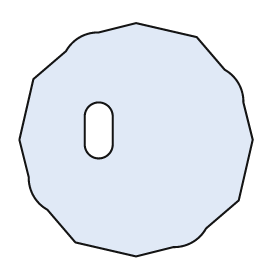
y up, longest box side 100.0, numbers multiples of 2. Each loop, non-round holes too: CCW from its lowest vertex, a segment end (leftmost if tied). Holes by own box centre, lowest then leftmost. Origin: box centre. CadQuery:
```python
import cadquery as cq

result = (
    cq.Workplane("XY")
    .moveTo(0.0, -50.0)
    .lineTo(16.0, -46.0)
    .threePointArc((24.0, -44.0), (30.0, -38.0))
    .lineTo(44.0, -26.0)
    .lineTo(50.0, 0.0)
    .lineTo(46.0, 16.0)
    .threePointArc((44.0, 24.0), (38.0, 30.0))
    .lineTo(26.0, 44.0)
    .lineTo(0.0, 50.0)
    .lineTo(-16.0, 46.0)
    .threePointArc((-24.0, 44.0), (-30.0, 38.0))
    .lineTo(-44.0, 26.0)
    .lineTo(-50.0, 0.0)
    .lineTo(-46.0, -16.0)
    .threePointArc((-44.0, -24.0), (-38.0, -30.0))
    .lineTo(-26.0, -44.0)
    .close()
    .moveTo(-22.0, -2.0)
    .threePointArc((-16.0, -8.0), (-10.0, -2.0))
    .lineTo(-10.0, 10.0)
    .threePointArc((-16.0, 16.0), (-22.0, 10.0))
    .close()
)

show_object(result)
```